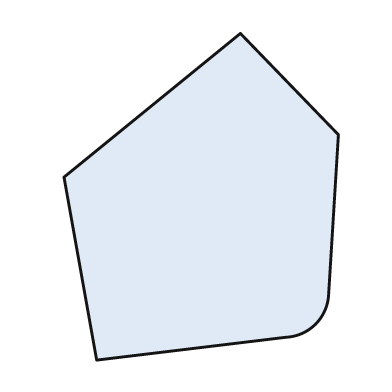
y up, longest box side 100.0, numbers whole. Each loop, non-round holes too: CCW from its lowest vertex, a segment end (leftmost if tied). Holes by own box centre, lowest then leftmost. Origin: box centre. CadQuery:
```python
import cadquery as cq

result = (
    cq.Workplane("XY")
    .moveTo(-32.0, -50.0)
    .lineTo(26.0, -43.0)
    .threePointArc((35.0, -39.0), (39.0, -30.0))
    .lineTo(42.0, 19.0)
    .lineTo(12.0, 50.0)
    .lineTo(-42.0, 6.0)
    .close()
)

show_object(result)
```